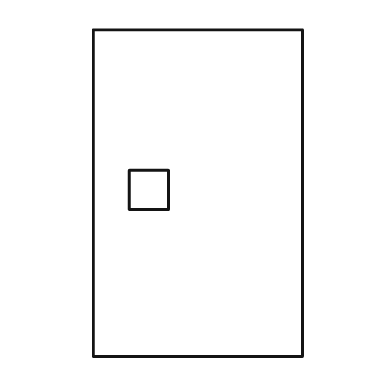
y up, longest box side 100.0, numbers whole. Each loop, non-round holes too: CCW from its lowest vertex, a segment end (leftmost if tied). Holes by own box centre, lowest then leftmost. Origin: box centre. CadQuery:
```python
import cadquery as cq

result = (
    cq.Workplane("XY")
    .moveTo(-32.0, -50.0)
    .lineTo(32.0, -50.0)
    .lineTo(32.0, 50.0)
    .lineTo(-32.0, 50.0)
    .close()
    .moveTo(-21.0, -5.0)
    .lineTo(-9.0, -5.0)
    .lineTo(-9.0, 7.0)
    .lineTo(-21.0, 7.0)
    .close()
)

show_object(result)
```